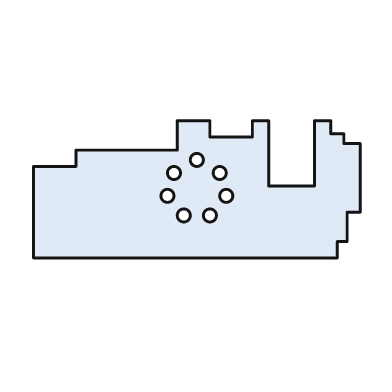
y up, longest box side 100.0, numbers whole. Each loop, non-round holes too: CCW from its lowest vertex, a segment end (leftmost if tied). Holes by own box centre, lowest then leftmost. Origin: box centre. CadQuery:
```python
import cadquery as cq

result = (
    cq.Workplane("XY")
    .moveTo(-50.0, -21.0)
    .lineTo(43.0, -21.0)
    .lineTo(43.0, -16.0)
    .lineTo(46.0, -16.0)
    .lineTo(46.0, -7.0)
    .lineTo(50.0, -7.0)
    .lineTo(50.0, 14.0)
    .lineTo(45.0, 14.0)
    .lineTo(45.0, 17.0)
    .lineTo(41.0, 17.0)
    .lineTo(41.0, 21.0)
    .lineTo(36.0, 21.0)
    .lineTo(36.0, 1.0)
    .lineTo(22.0, 1.0)
    .lineTo(22.0, 21.0)
    .lineTo(17.0, 21.0)
    .lineTo(17.0, 16.0)
    .lineTo(4.0, 16.0)
    .lineTo(4.0, 21.0)
    .lineTo(-6.0, 21.0)
    .lineTo(-6.0, 12.0)
    .lineTo(-37.0, 12.0)
    .lineTo(-37.0, 7.0)
    .lineTo(-50.0, 7.0)
    .close()
    .moveTo(-4.0, -8.0)
    .circle(2.0)
    .moveTo(4.0, -8.0)
    .circle(2.0)
    .moveTo(-9.0, -2.0)
    .circle(2.0)
    .moveTo(9.0, -2.0)
    .circle(2.0)
    .moveTo(-7.0, 5.0)
    .circle(2.0)
    .moveTo(7.0, 5.0)
    .circle(2.0)
    .moveTo(0.0, 9.0)
    .circle(2.0)
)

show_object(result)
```